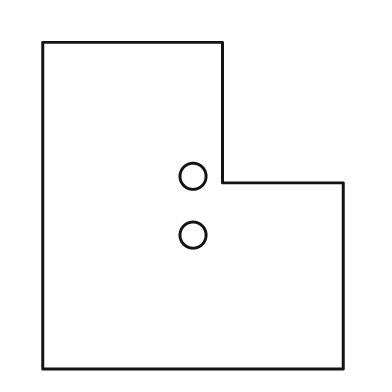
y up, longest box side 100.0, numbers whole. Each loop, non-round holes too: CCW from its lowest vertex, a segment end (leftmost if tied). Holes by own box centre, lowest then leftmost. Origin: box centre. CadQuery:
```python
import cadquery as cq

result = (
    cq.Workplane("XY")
    .moveTo(-46.0, -50.0)
    .lineTo(46.0, -50.0)
    .lineTo(46.0, 7.0)
    .lineTo(9.0, 7.0)
    .lineTo(9.0, 50.0)
    .lineTo(-46.0, 50.0)
    .close()
    .moveTo(0.0, -9.0)
    .circle(4.0)
    .moveTo(0.0, 9.0)
    .circle(4.0)
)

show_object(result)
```